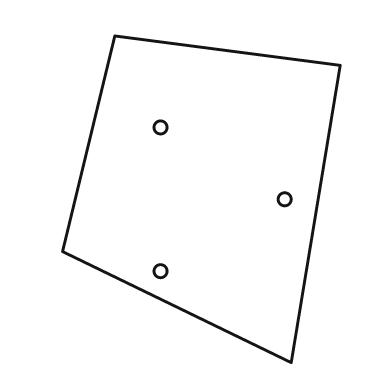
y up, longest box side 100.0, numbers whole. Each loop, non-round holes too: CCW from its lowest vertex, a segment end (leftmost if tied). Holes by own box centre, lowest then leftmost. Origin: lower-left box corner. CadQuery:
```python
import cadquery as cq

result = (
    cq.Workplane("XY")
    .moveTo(70.0, 0.0)
    .lineTo(85.0, 91.0)
    .lineTo(16.0, 100.0)
    .lineTo(0.0, 34.0)
    .close()
    .moveTo(30.0, 28.0)
    .circle(2.0)
    .moveTo(68.0, 50.0)
    .circle(2.0)
    .moveTo(30.0, 72.0)
    .circle(2.0)
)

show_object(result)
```